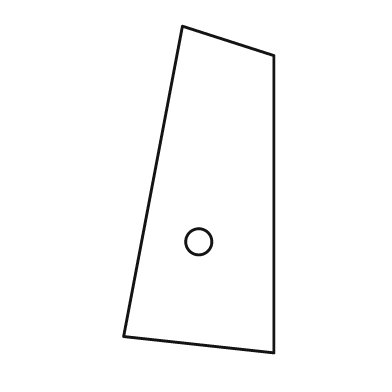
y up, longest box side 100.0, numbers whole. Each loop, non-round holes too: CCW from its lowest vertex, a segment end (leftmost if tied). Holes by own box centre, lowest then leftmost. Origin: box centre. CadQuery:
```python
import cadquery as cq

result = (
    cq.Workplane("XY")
    .moveTo(23.0, -50.0)
    .lineTo(23.0, 41.0)
    .lineTo(-5.0, 50.0)
    .lineTo(-23.0, -45.0)
    .close()
    .moveTo(0.0, -16.0)
    .circle(4.0)
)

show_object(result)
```